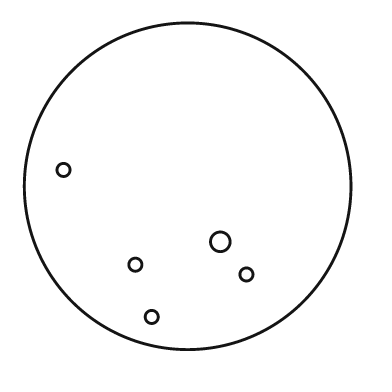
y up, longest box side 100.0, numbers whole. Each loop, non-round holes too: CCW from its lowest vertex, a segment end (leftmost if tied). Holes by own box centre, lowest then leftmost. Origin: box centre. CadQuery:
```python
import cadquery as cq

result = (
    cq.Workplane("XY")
    .moveTo(0.0, 0.0)
    .circle(50.0)
    .moveTo(-11.0, -40.0)
    .circle(2.0)
    .moveTo(18.0, -27.0)
    .circle(2.0)
    .moveTo(-16.0, -24.0)
    .circle(2.0)
    .moveTo(10.0, -17.0)
    .circle(3.0)
    .moveTo(-38.0, 5.0)
    .circle(2.0)
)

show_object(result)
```